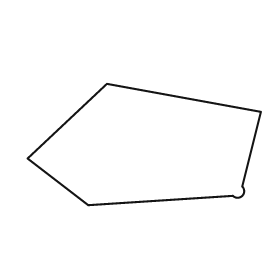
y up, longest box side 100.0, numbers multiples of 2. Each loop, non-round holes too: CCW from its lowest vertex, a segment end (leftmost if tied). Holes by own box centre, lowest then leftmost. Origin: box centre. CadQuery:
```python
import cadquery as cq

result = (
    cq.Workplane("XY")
    .moveTo(-24.0, -26.0)
    .lineTo(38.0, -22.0)
    .threePointArc((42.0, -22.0), (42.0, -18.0))
    .lineTo(50.0, 14.0)
    .lineTo(-16.0, 26.0)
    .lineTo(-50.0, -6.0)
    .close()
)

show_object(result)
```